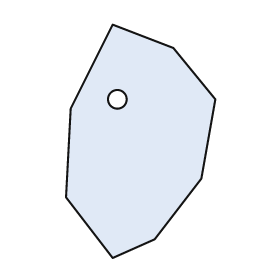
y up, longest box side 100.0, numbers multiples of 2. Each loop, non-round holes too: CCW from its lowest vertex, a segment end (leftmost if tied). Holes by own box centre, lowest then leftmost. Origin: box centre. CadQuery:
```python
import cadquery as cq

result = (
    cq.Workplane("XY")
    .moveTo(-12.0, -50.0)
    .lineTo(6.0, -42.0)
    .lineTo(26.0, -16.0)
    .lineTo(32.0, 18.0)
    .lineTo(14.0, 40.0)
    .lineTo(-12.0, 50.0)
    .lineTo(-30.0, 14.0)
    .lineTo(-32.0, -24.0)
    .close()
    .moveTo(-10.0, 18.0)
    .circle(4.0)
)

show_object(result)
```